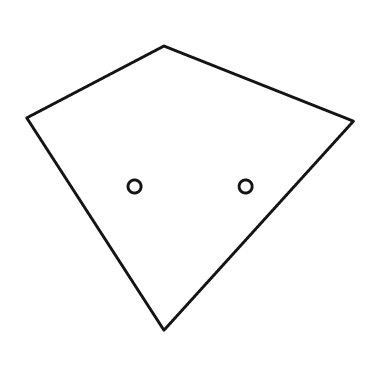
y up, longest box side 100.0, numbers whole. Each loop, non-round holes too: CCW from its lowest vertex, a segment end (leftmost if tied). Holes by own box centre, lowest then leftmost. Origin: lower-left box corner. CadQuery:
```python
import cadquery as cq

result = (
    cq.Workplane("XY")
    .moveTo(42.0, 0.0)
    .lineTo(100.0, 64.0)
    .lineTo(42.0, 87.0)
    .lineTo(0.0, 65.0)
    .close()
    .moveTo(33.0, 44.0)
    .circle(2.0)
    .moveTo(67.0, 44.0)
    .circle(2.0)
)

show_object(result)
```